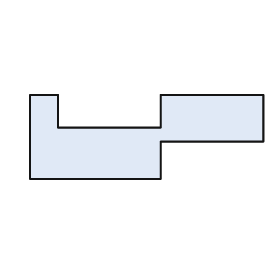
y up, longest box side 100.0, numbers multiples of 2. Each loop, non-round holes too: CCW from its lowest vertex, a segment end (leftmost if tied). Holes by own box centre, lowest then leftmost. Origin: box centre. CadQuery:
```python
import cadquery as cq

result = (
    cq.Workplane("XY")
    .moveTo(-50.0, -18.0)
    .lineTo(6.0, -18.0)
    .lineTo(6.0, -2.0)
    .lineTo(50.0, -2.0)
    .lineTo(50.0, 18.0)
    .lineTo(6.0, 18.0)
    .lineTo(6.0, 4.0)
    .lineTo(-38.0, 4.0)
    .lineTo(-38.0, 18.0)
    .lineTo(-50.0, 18.0)
    .close()
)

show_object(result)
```